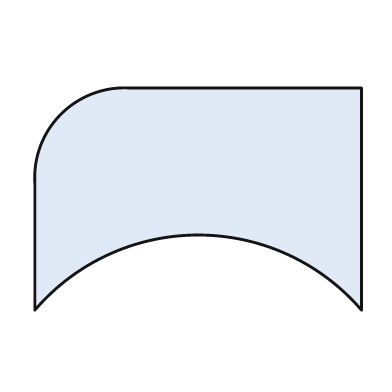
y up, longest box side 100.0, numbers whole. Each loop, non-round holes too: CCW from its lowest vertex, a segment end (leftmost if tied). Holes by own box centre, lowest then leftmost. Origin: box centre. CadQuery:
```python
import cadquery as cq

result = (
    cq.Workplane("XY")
    .moveTo(-50.0, -34.0)
    .threePointArc((0.0, -11.0), (50.0, -34.0))
    .lineTo(50.0, 34.0)
    .lineTo(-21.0, 34.0)
    .threePointArc((-42.0, 26.0), (-50.0, 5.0))
    .close()
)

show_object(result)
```